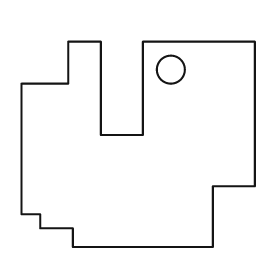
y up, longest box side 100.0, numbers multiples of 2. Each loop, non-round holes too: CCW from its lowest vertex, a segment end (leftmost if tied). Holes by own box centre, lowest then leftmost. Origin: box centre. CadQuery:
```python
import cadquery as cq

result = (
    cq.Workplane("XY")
    .moveTo(-28.0, -44.0)
    .lineTo(32.0, -44.0)
    .lineTo(32.0, -18.0)
    .lineTo(50.0, -18.0)
    .lineTo(50.0, 44.0)
    .lineTo(2.0, 44.0)
    .lineTo(2.0, 4.0)
    .lineTo(-16.0, 4.0)
    .lineTo(-16.0, 44.0)
    .lineTo(-30.0, 44.0)
    .lineTo(-30.0, 26.0)
    .lineTo(-50.0, 26.0)
    .lineTo(-50.0, -30.0)
    .lineTo(-42.0, -30.0)
    .lineTo(-42.0, -36.0)
    .lineTo(-28.0, -36.0)
    .close()
    .moveTo(14.0, 32.0)
    .circle(6.0)
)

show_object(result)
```